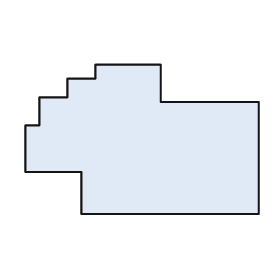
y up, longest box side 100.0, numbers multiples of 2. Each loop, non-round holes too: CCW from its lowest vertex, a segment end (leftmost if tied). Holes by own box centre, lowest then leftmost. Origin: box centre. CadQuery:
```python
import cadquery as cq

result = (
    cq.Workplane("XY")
    .moveTo(-26.0, -32.0)
    .lineTo(50.0, -32.0)
    .lineTo(50.0, 16.0)
    .lineTo(8.0, 16.0)
    .lineTo(8.0, 32.0)
    .lineTo(-20.0, 32.0)
    .lineTo(-20.0, 26.0)
    .lineTo(-32.0, 26.0)
    .lineTo(-32.0, 18.0)
    .lineTo(-44.0, 18.0)
    .lineTo(-44.0, 6.0)
    .lineTo(-50.0, 6.0)
    .lineTo(-50.0, -14.0)
    .lineTo(-26.0, -14.0)
    .close()
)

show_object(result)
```